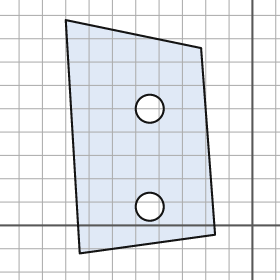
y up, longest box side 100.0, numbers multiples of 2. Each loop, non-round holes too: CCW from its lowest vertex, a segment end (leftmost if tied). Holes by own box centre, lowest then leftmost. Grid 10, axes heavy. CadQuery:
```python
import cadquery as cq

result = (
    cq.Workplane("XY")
    .moveTo(-74.0, -12.0)
    .lineTo(-16.0, -4.0)
    .lineTo(-22.0, 76.0)
    .lineTo(-80.0, 88.0)
    .close()
    .moveTo(-44.0, 8.0)
    .circle(6.0)
    .moveTo(-44.0, 50.0)
    .circle(6.0)
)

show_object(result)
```